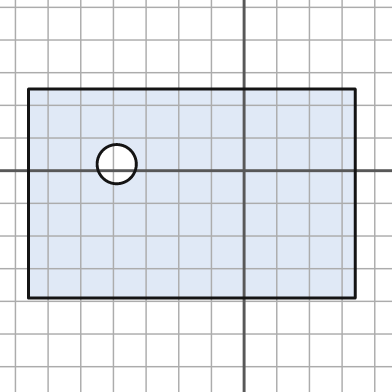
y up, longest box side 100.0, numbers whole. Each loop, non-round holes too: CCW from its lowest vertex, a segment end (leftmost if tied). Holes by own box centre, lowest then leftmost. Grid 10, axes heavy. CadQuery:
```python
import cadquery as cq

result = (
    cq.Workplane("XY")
    .moveTo(-66.0, -39.0)
    .lineTo(34.0, -39.0)
    .lineTo(34.0, 25.0)
    .lineTo(-66.0, 25.0)
    .close()
    .moveTo(-39.0, 2.0)
    .circle(6.0)
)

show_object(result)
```